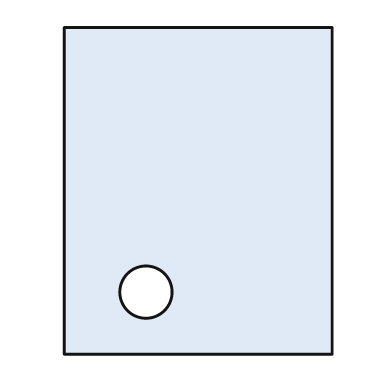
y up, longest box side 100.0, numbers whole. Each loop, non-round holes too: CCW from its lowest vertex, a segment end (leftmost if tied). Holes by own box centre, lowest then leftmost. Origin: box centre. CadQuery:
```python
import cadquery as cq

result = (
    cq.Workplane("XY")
    .moveTo(-41.0, -50.0)
    .lineTo(41.0, -50.0)
    .lineTo(41.0, 50.0)
    .lineTo(-41.0, 50.0)
    .close()
    .moveTo(-16.0, -31.0)
    .circle(8.0)
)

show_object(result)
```